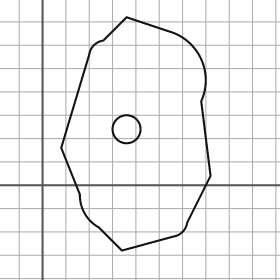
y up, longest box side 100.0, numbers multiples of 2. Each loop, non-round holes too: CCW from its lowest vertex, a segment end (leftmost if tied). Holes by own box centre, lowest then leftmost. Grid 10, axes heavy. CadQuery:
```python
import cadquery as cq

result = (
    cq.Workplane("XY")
    .moveTo(34.0, -28.0)
    .lineTo(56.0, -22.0)
    .threePointArc((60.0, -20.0), (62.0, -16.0))
    .lineTo(72.0, 4.0)
    .lineTo(68.0, 36.0)
    .threePointArc((68.0, 54.0), (54.0, 66.0))
    .lineTo(36.0, 72.0)
    .lineTo(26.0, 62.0)
    .threePointArc((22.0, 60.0), (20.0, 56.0))
    .lineTo(8.0, 16.0)
    .lineTo(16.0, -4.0)
    .threePointArc((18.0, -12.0), (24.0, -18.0))
    .close()
    .moveTo(36.0, 24.0)
    .circle(6.0)
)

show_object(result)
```